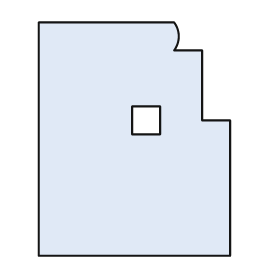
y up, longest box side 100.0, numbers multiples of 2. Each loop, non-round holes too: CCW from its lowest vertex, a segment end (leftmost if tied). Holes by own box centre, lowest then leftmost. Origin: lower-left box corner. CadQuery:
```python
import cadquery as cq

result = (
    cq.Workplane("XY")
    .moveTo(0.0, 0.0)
    .lineTo(82.0, 0.0)
    .lineTo(82.0, 58.0)
    .lineTo(70.0, 58.0)
    .lineTo(70.0, 88.0)
    .lineTo(58.0, 88.0)
    .threePointArc((60.0, 94.0), (58.0, 100.0))
    .lineTo(0.0, 100.0)
    .close()
    .moveTo(40.0, 52.0)
    .lineTo(52.0, 52.0)
    .lineTo(52.0, 64.0)
    .lineTo(40.0, 64.0)
    .close()
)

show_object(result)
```